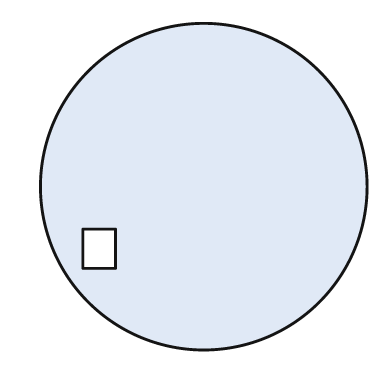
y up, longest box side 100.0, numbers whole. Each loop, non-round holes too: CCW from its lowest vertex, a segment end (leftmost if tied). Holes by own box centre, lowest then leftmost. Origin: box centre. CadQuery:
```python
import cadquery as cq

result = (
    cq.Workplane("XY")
    .moveTo(0.0, 0.0)
    .circle(50.0)
    .moveTo(-37.0, -25.0)
    .lineTo(-27.0, -25.0)
    .lineTo(-27.0, -13.0)
    .lineTo(-37.0, -13.0)
    .close()
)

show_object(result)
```